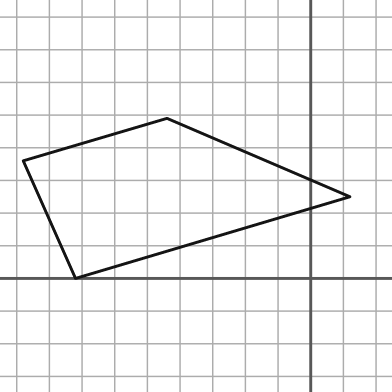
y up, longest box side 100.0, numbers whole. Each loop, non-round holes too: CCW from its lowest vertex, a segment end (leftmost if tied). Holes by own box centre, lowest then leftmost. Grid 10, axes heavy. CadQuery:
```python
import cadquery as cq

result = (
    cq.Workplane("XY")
    .moveTo(-72.0, 0.0)
    .lineTo(12.0, 25.0)
    .lineTo(-44.0, 49.0)
    .lineTo(-88.0, 36.0)
    .close()
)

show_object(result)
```